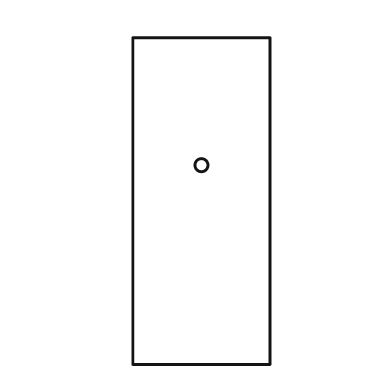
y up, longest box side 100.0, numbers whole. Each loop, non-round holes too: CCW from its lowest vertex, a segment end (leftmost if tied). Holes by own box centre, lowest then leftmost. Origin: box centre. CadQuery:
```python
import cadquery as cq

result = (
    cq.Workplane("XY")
    .moveTo(-21.0, -50.0)
    .lineTo(21.0, -50.0)
    .lineTo(21.0, 50.0)
    .lineTo(-21.0, 50.0)
    .close()
    .moveTo(0.0, 11.0)
    .circle(2.0)
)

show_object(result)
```